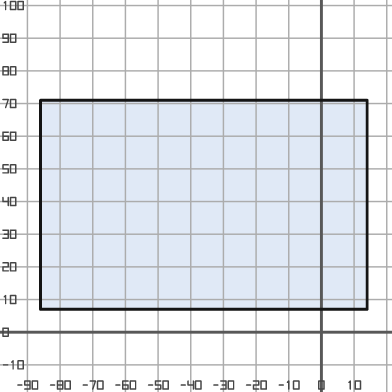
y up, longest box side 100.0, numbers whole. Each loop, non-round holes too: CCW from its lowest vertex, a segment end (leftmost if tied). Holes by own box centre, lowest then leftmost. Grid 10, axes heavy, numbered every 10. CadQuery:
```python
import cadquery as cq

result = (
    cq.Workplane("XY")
    .moveTo(-86.0, 7.0)
    .lineTo(14.0, 7.0)
    .lineTo(14.0, 71.0)
    .lineTo(-86.0, 71.0)
    .close()
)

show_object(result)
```